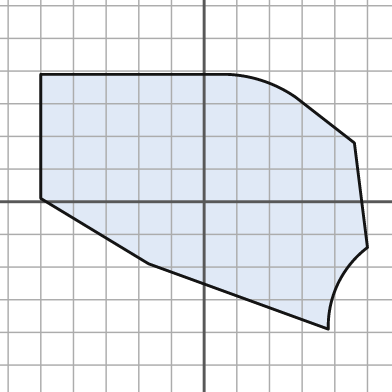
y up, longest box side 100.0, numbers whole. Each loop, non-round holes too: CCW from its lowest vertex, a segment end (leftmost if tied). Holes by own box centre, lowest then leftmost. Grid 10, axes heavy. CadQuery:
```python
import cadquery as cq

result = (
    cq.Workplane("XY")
    .moveTo(38.0, -39.0)
    .threePointArc((41.0, -25.0), (50.0, -14.0))
    .lineTo(46.0, 18.0)
    .lineTo(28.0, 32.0)
    .threePointArc((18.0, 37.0), (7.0, 39.0))
    .lineTo(-50.0, 39.0)
    .lineTo(-50.0, 1.0)
    .lineTo(-17.0, -19.0)
    .close()
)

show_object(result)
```